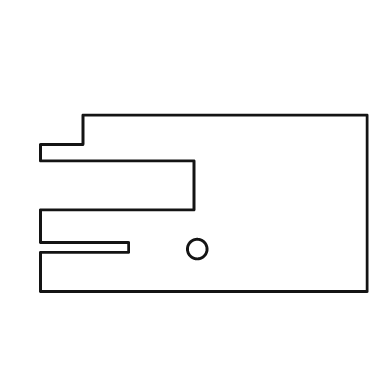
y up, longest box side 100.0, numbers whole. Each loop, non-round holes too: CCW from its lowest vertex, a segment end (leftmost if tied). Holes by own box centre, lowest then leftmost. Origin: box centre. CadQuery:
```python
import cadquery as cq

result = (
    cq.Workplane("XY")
    .moveTo(-50.0, -27.0)
    .lineTo(50.0, -27.0)
    .lineTo(50.0, 27.0)
    .lineTo(-37.0, 27.0)
    .lineTo(-37.0, 18.0)
    .lineTo(-50.0, 18.0)
    .lineTo(-50.0, 13.0)
    .lineTo(-3.0, 13.0)
    .lineTo(-3.0, -2.0)
    .lineTo(-50.0, -2.0)
    .lineTo(-50.0, -12.0)
    .lineTo(-23.0, -12.0)
    .lineTo(-23.0, -15.0)
    .lineTo(-50.0, -15.0)
    .close()
    .moveTo(-2.0, -14.0)
    .circle(3.0)
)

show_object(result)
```